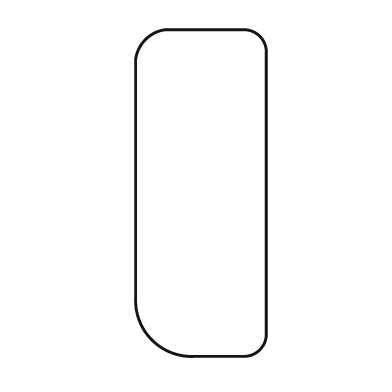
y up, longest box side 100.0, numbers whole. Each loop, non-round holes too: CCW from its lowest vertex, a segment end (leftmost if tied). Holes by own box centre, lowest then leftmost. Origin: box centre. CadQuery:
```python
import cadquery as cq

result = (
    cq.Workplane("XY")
    .moveTo(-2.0, -50.0)
    .lineTo(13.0, -50.0)
    .threePointArc((18.0, -48.0), (20.0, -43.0))
    .lineTo(20.0, 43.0)
    .threePointArc((18.0, 48.0), (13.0, 50.0))
    .lineTo(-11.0, 50.0)
    .threePointArc((-17.0, 47.0), (-20.0, 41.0))
    .lineTo(-20.0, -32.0)
    .threePointArc((-15.0, -45.0), (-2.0, -50.0))
    .close()
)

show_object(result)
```